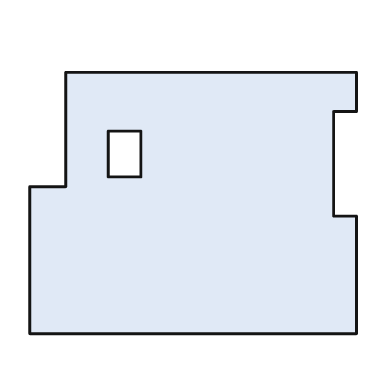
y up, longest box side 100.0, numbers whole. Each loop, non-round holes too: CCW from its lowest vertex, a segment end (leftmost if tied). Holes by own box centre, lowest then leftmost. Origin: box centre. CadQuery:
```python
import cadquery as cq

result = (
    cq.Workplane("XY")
    .moveTo(-50.0, -40.0)
    .lineTo(50.0, -40.0)
    .lineTo(50.0, -4.0)
    .lineTo(43.0, -4.0)
    .lineTo(43.0, 28.0)
    .lineTo(50.0, 28.0)
    .lineTo(50.0, 40.0)
    .lineTo(-39.0, 40.0)
    .lineTo(-39.0, 5.0)
    .lineTo(-50.0, 5.0)
    .close()
    .moveTo(-26.0, 8.0)
    .lineTo(-16.0, 8.0)
    .lineTo(-16.0, 22.0)
    .lineTo(-26.0, 22.0)
    .close()
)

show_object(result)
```